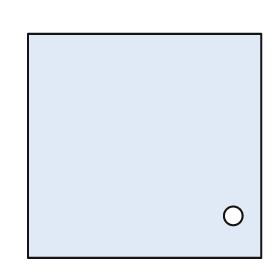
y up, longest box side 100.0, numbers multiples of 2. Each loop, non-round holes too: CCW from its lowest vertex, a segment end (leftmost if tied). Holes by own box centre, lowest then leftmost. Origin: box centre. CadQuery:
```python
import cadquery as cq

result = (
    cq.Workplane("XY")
    .moveTo(-50.0, -48.0)
    .lineTo(50.0, -48.0)
    .lineTo(50.0, 48.0)
    .lineTo(-50.0, 48.0)
    .close()
    .moveTo(38.0, -30.0)
    .circle(4.0)
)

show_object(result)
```